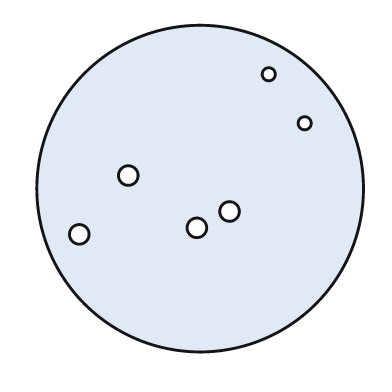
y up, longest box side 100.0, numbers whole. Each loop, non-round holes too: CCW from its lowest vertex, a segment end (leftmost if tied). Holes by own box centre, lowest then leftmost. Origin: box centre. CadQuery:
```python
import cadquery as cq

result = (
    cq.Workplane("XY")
    .moveTo(0.0, 0.0)
    .circle(50.0)
    .moveTo(-37.0, -14.0)
    .circle(3.0)
    .moveTo(-1.0, -12.0)
    .circle(3.0)
    .moveTo(9.0, -7.0)
    .circle(3.0)
    .moveTo(-22.0, 4.0)
    .circle(3.0)
    .moveTo(32.0, 20.0)
    .circle(2.0)
    .moveTo(21.0, 35.0)
    .circle(2.0)
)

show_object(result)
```